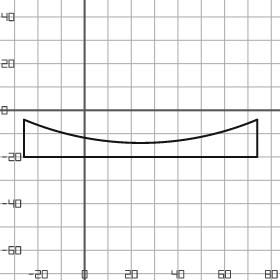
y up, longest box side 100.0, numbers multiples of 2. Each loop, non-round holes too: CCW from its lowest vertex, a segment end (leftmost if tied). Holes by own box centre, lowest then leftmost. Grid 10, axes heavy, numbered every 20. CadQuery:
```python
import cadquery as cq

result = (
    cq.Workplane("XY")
    .moveTo(-26.0, -20.0)
    .lineTo(74.0, -20.0)
    .lineTo(74.0, -4.0)
    .threePointArc((24.0, -14.0), (-26.0, -4.0))
    .close()
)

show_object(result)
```